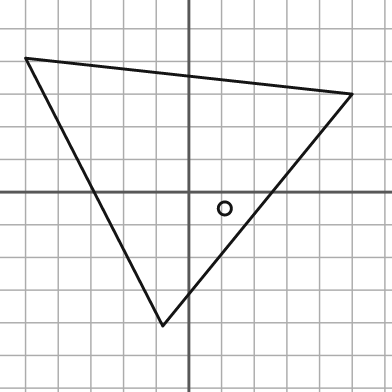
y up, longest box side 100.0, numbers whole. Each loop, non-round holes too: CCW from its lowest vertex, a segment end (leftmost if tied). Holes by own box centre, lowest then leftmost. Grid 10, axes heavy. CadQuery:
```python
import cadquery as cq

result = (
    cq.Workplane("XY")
    .moveTo(-8.0, -41.0)
    .lineTo(50.0, 30.0)
    .lineTo(-50.0, 41.0)
    .close()
    .moveTo(11.0, -5.0)
    .circle(2.0)
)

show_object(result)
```